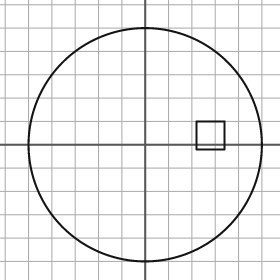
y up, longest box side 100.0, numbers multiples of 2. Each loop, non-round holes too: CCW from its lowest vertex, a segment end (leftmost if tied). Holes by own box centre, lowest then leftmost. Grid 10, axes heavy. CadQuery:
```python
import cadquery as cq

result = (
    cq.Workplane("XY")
    .moveTo(0.0, 0.0)
    .circle(50.0)
    .moveTo(22.0, -2.0)
    .lineTo(34.0, -2.0)
    .lineTo(34.0, 10.0)
    .lineTo(22.0, 10.0)
    .close()
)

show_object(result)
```